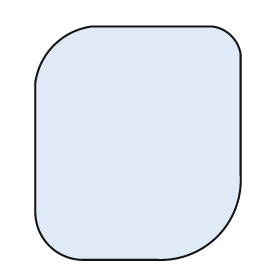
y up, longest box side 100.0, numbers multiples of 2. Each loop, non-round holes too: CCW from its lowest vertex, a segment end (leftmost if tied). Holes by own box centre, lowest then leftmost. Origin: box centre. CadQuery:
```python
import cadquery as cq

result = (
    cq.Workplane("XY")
    .moveTo(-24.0, -50.0)
    .lineTo(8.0, -50.0)
    .threePointArc((34.0, -40.0), (44.0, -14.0))
    .lineTo(44.0, 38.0)
    .threePointArc((40.0, 46.0), (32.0, 50.0))
    .lineTo(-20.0, 50.0)
    .threePointArc((-36.0, 42.0), (-44.0, 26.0))
    .lineTo(-44.0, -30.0)
    .threePointArc((-38.0, -44.0), (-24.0, -50.0))
    .close()
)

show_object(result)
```